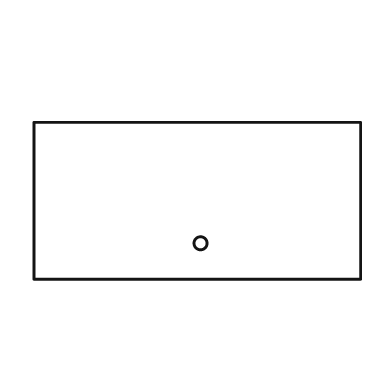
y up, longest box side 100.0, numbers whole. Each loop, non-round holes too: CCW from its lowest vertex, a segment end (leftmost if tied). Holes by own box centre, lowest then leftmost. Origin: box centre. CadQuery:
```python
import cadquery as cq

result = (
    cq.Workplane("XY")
    .moveTo(-50.0, -24.0)
    .lineTo(50.0, -24.0)
    .lineTo(50.0, 24.0)
    .lineTo(-50.0, 24.0)
    .close()
    .moveTo(1.0, -13.0)
    .circle(2.0)
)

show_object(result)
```